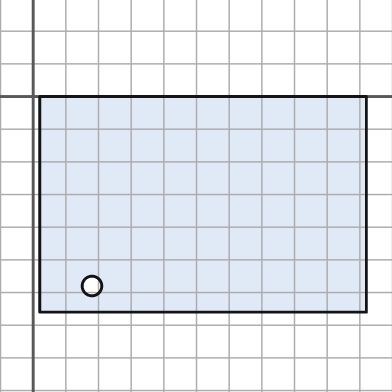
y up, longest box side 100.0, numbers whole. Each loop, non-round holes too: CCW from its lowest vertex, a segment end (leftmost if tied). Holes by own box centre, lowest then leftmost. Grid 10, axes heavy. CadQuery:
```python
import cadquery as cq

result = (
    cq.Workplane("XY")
    .moveTo(2.0, -66.0)
    .lineTo(102.0, -66.0)
    .lineTo(102.0, 0.0)
    .lineTo(2.0, 0.0)
    .close()
    .moveTo(18.0, -58.0)
    .circle(3.0)
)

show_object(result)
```